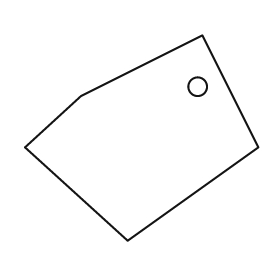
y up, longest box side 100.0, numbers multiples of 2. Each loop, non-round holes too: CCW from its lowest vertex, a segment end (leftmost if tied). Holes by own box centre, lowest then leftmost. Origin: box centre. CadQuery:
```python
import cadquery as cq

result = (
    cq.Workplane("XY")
    .moveTo(-6.0, -44.0)
    .lineTo(50.0, -4.0)
    .lineTo(26.0, 44.0)
    .lineTo(-26.0, 18.0)
    .lineTo(-50.0, -4.0)
    .close()
    .moveTo(24.0, 22.0)
    .circle(4.0)
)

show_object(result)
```